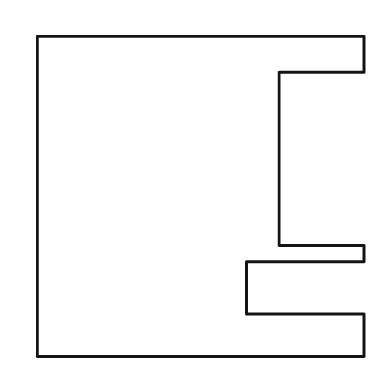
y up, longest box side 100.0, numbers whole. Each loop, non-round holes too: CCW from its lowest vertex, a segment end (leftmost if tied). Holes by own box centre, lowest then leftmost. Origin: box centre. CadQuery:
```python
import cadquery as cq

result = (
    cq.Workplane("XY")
    .moveTo(-50.0, -49.0)
    .lineTo(50.0, -49.0)
    .lineTo(50.0, -36.0)
    .lineTo(14.0, -36.0)
    .lineTo(14.0, -20.0)
    .lineTo(50.0, -20.0)
    .lineTo(50.0, -15.0)
    .lineTo(24.0, -15.0)
    .lineTo(24.0, 38.0)
    .lineTo(50.0, 38.0)
    .lineTo(50.0, 49.0)
    .lineTo(-50.0, 49.0)
    .close()
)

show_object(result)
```